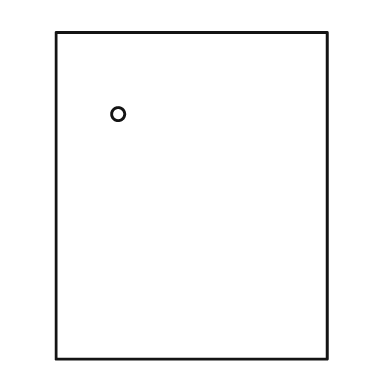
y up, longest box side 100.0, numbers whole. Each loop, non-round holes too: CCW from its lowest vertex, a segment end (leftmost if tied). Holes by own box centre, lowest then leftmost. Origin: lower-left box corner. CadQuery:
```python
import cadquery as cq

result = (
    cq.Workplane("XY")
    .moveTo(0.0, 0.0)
    .lineTo(83.0, 0.0)
    .lineTo(83.0, 100.0)
    .lineTo(0.0, 100.0)
    .close()
    .moveTo(19.0, 75.0)
    .circle(2.0)
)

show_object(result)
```